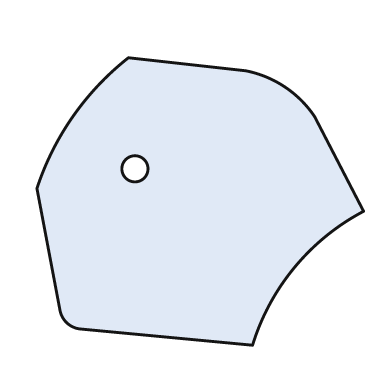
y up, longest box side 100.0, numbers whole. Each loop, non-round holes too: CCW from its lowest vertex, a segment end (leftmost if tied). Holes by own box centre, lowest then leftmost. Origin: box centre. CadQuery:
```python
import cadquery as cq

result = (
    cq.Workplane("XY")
    .moveTo(16.0, -44.0)
    .threePointArc((29.0, -20.0), (50.0, -3.0))
    .lineTo(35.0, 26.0)
    .threePointArc((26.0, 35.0), (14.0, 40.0))
    .lineTo(-22.0, 44.0)
    .threePointArc((-39.0, 26.0), (-50.0, 4.0))
    .lineTo(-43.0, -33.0)
    .threePointArc((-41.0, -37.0), (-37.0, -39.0))
    .close()
    .moveTo(-20.0, 10.0)
    .circle(4.0)
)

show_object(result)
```